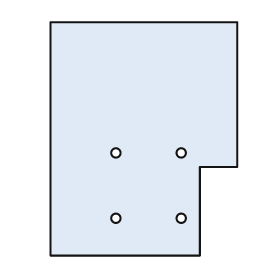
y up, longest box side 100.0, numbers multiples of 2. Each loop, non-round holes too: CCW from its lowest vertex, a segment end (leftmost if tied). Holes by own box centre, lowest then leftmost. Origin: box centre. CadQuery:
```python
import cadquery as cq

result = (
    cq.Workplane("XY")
    .moveTo(-40.0, -50.0)
    .lineTo(24.0, -50.0)
    .lineTo(24.0, -12.0)
    .lineTo(40.0, -12.0)
    .lineTo(40.0, 50.0)
    .lineTo(-40.0, 50.0)
    .close()
    .moveTo(-12.0, -34.0)
    .circle(2.0)
    .moveTo(16.0, -34.0)
    .circle(2.0)
    .moveTo(-12.0, -6.0)
    .circle(2.0)
    .moveTo(16.0, -6.0)
    .circle(2.0)
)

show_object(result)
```